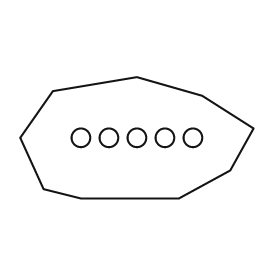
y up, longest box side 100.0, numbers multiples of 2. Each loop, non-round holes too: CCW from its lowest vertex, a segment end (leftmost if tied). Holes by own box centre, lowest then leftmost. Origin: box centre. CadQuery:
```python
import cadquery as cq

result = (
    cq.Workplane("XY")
    .moveTo(-24.0, -26.0)
    .lineTo(18.0, -26.0)
    .lineTo(40.0, -14.0)
    .lineTo(50.0, 4.0)
    .lineTo(28.0, 18.0)
    .lineTo(0.0, 26.0)
    .lineTo(-36.0, 20.0)
    .lineTo(-50.0, 0.0)
    .lineTo(-40.0, -22.0)
    .close()
    .moveTo(-24.0, 0.0)
    .circle(4.0)
    .moveTo(-12.0, 0.0)
    .circle(4.0)
    .moveTo(0.0, 0.0)
    .circle(4.0)
    .moveTo(12.0, 0.0)
    .circle(4.0)
    .moveTo(24.0, 0.0)
    .circle(4.0)
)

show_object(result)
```